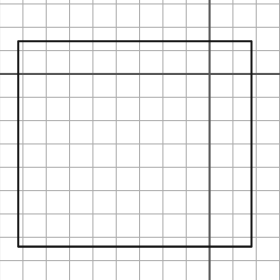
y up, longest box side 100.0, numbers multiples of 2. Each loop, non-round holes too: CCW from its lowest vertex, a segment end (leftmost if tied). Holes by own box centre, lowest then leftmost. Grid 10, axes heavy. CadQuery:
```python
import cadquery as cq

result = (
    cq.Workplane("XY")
    .moveTo(-82.0, -74.0)
    .lineTo(18.0, -74.0)
    .lineTo(18.0, 14.0)
    .lineTo(-82.0, 14.0)
    .close()
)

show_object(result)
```